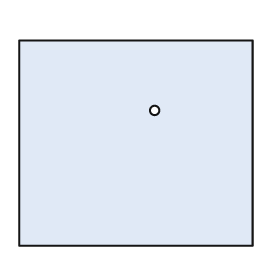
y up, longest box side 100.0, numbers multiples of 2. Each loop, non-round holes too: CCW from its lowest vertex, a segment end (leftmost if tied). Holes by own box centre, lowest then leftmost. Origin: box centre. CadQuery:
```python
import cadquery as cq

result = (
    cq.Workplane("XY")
    .moveTo(-50.0, -44.0)
    .lineTo(50.0, -44.0)
    .lineTo(50.0, 44.0)
    .lineTo(-50.0, 44.0)
    .close()
    .moveTo(8.0, 14.0)
    .circle(2.0)
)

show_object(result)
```